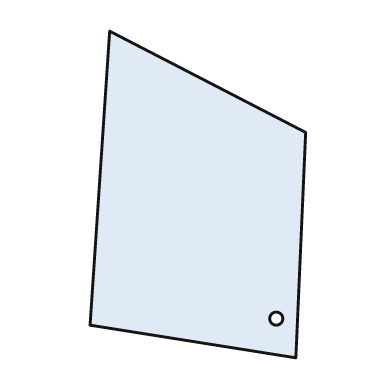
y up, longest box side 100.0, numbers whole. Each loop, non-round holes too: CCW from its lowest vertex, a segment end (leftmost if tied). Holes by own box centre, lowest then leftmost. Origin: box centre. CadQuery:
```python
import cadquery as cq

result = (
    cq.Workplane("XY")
    .moveTo(30.0, -50.0)
    .lineTo(33.0, 19.0)
    .lineTo(-27.0, 50.0)
    .lineTo(-33.0, -40.0)
    .close()
    .moveTo(24.0, -38.0)
    .circle(2.0)
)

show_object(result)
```